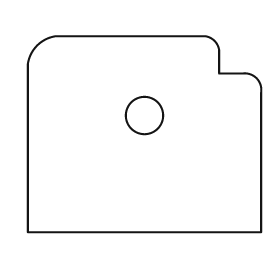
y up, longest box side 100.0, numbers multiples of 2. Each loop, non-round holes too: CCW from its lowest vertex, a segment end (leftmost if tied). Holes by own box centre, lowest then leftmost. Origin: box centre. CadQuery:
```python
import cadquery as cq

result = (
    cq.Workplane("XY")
    .moveTo(-50.0, -42.0)
    .lineTo(50.0, -42.0)
    .lineTo(50.0, 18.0)
    .threePointArc((48.0, 24.0), (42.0, 26.0))
    .lineTo(32.0, 26.0)
    .lineTo(32.0, 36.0)
    .threePointArc((30.0, 40.0), (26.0, 42.0))
    .lineTo(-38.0, 42.0)
    .threePointArc((-46.0, 38.0), (-50.0, 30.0))
    .close()
    .moveTo(0.0, 8.0)
    .circle(8.0)
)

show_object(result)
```